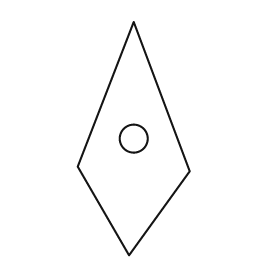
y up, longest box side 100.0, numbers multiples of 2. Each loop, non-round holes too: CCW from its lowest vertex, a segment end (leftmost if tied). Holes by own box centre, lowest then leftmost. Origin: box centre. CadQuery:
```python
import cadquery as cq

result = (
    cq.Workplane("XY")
    .moveTo(-2.0, -50.0)
    .lineTo(24.0, -14.0)
    .lineTo(0.0, 50.0)
    .lineTo(-24.0, -12.0)
    .close()
    .moveTo(0.0, 0.0)
    .circle(6.0)
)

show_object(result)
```